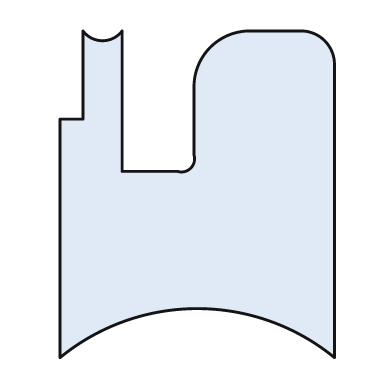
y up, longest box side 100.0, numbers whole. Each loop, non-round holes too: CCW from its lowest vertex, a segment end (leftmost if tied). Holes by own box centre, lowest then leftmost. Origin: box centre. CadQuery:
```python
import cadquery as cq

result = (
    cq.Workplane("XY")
    .moveTo(-42.0, -50.0)
    .threePointArc((0.0, -35.0), (42.0, -50.0))
    .lineTo(42.0, 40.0)
    .threePointArc((39.0, 47.0), (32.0, 50.0))
    .lineTo(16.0, 50.0)
    .threePointArc((4.0, 45.0), (-1.0, 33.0))
    .lineTo(-1.0, 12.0)
    .threePointArc((-2.0, 8.0), (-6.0, 7.0))
    .lineTo(-23.0, 7.0)
    .lineTo(-23.0, 50.0)
    .threePointArc((-29.0, 47.0), (-35.0, 50.0))
    .lineTo(-35.0, 23.0)
    .lineTo(-42.0, 23.0)
    .close()
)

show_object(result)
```